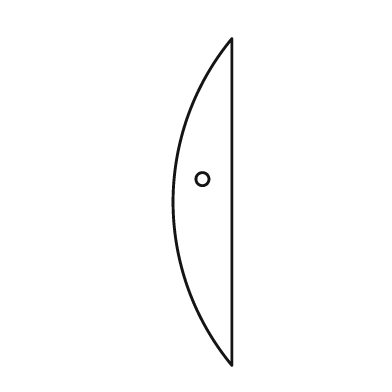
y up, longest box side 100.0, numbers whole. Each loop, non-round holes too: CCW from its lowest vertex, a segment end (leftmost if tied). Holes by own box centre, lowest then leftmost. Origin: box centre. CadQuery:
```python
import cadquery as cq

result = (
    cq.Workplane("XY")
    .moveTo(9.0, -50.0)
    .lineTo(9.0, 50.0)
    .threePointArc((-9.0, 0.0), (9.0, -50.0))
    .close()
    .moveTo(0.0, 7.0)
    .circle(2.0)
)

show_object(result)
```